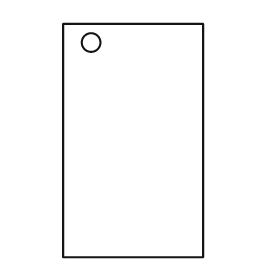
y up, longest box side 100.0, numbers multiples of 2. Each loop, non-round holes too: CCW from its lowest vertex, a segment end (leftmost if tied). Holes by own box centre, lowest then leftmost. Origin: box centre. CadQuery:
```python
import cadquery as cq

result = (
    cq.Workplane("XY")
    .moveTo(-30.0, -50.0)
    .lineTo(30.0, -50.0)
    .lineTo(30.0, 50.0)
    .lineTo(-30.0, 50.0)
    .close()
    .moveTo(-18.0, 42.0)
    .circle(4.0)
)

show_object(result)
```